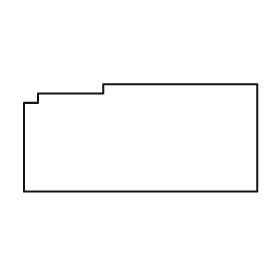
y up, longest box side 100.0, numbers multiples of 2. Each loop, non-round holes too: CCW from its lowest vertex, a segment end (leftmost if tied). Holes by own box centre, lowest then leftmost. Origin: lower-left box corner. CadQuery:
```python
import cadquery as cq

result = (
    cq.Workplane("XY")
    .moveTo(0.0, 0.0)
    .lineTo(100.0, 0.0)
    .lineTo(100.0, 46.0)
    .lineTo(34.0, 46.0)
    .lineTo(34.0, 42.0)
    .lineTo(6.0, 42.0)
    .lineTo(6.0, 38.0)
    .lineTo(0.0, 38.0)
    .close()
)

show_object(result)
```